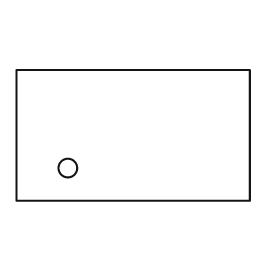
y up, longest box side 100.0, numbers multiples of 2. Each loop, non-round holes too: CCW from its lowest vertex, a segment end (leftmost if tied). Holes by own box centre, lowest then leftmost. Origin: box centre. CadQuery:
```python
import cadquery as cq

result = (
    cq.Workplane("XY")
    .moveTo(-50.0, -28.0)
    .lineTo(50.0, -28.0)
    .lineTo(50.0, 28.0)
    .lineTo(-50.0, 28.0)
    .close()
    .moveTo(-28.0, -14.0)
    .circle(4.0)
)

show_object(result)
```